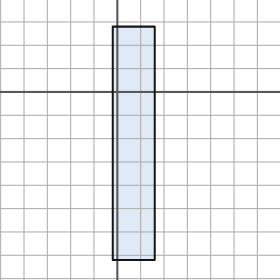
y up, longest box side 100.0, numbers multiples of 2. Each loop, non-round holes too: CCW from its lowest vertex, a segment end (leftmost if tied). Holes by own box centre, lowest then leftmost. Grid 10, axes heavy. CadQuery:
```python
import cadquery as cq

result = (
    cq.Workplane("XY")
    .moveTo(-2.0, -72.0)
    .lineTo(16.0, -72.0)
    .lineTo(16.0, 28.0)
    .lineTo(-2.0, 28.0)
    .close()
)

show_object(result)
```